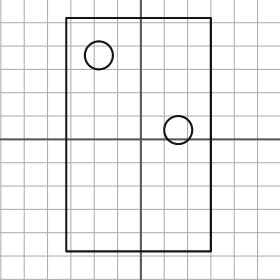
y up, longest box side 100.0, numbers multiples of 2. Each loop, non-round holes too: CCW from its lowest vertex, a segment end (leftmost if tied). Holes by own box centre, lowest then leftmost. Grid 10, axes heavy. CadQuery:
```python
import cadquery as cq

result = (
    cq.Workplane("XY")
    .moveTo(-32.0, -48.0)
    .lineTo(30.0, -48.0)
    .lineTo(30.0, 52.0)
    .lineTo(-32.0, 52.0)
    .close()
    .moveTo(16.0, 4.0)
    .circle(6.0)
    .moveTo(-18.0, 36.0)
    .circle(6.0)
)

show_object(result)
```